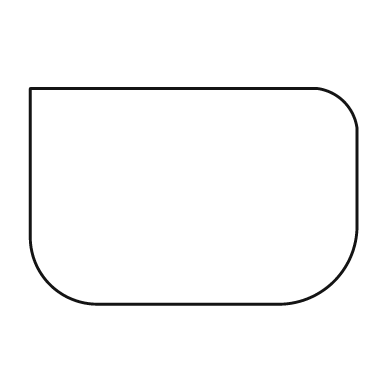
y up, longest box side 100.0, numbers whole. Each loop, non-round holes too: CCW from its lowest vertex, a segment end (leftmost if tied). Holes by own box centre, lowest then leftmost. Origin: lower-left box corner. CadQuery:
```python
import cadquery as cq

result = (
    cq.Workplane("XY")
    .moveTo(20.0, 0.0)
    .lineTo(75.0, 0.0)
    .threePointArc((93.0, 7.0), (100.0, 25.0))
    .lineTo(100.0, 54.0)
    .threePointArc((96.0, 62.0), (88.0, 66.0))
    .lineTo(0.0, 66.0)
    .lineTo(0.0, 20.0)
    .threePointArc((6.0, 6.0), (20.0, 0.0))
    .close()
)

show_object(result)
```